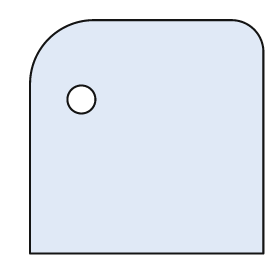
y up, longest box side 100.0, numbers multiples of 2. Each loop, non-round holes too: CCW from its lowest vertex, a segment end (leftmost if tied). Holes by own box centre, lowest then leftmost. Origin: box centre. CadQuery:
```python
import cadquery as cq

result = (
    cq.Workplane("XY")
    .moveTo(-50.0, -50.0)
    .lineTo(50.0, -50.0)
    .lineTo(50.0, 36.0)
    .threePointArc((46.0, 46.0), (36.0, 50.0))
    .lineTo(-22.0, 50.0)
    .threePointArc((-42.0, 42.0), (-50.0, 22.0))
    .close()
    .moveTo(-28.0, 16.0)
    .circle(6.0)
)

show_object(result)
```